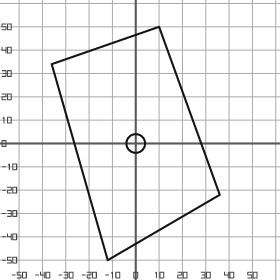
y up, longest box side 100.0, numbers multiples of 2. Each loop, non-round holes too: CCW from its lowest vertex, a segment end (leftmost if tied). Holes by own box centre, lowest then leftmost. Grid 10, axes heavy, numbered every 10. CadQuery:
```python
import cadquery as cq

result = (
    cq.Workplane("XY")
    .moveTo(-12.0, -50.0)
    .lineTo(36.0, -22.0)
    .lineTo(10.0, 50.0)
    .lineTo(-36.0, 34.0)
    .close()
    .moveTo(0.0, 0.0)
    .circle(4.0)
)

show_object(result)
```